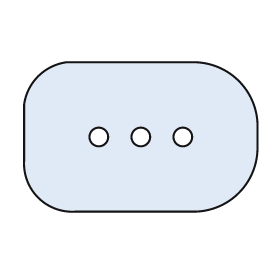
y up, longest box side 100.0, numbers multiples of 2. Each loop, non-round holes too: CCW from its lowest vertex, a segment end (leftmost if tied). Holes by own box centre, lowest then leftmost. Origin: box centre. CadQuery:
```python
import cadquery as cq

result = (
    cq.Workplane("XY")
    .moveTo(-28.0, -32.0)
    .lineTo(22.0, -32.0)
    .threePointArc((42.0, -24.0), (50.0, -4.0))
    .lineTo(50.0, 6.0)
    .threePointArc((42.0, 24.0), (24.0, 32.0))
    .lineTo(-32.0, 32.0)
    .threePointArc((-44.0, 26.0), (-50.0, 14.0))
    .lineTo(-50.0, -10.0)
    .threePointArc((-44.0, -26.0), (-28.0, -32.0))
    .close()
    .moveTo(-18.0, 0.0)
    .circle(4.0)
    .moveTo(0.0, 0.0)
    .circle(4.0)
    .moveTo(18.0, 0.0)
    .circle(4.0)
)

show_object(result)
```